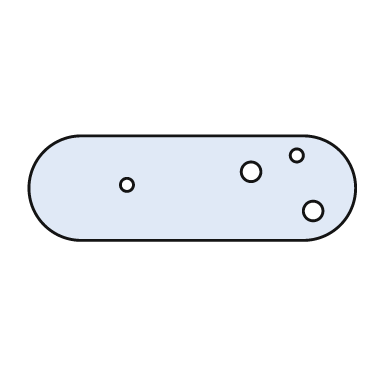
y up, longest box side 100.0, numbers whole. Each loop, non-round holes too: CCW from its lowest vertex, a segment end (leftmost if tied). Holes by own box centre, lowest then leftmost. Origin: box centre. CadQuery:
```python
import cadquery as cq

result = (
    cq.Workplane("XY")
    .moveTo(-34.0, -16.0)
    .lineTo(34.0, -16.0)
    .threePointArc((50.0, 0.0), (34.0, 16.0))
    .lineTo(-34.0, 16.0)
    .threePointArc((-50.0, 0.0), (-34.0, -16.0))
    .close()
    .moveTo(37.0, -7.0)
    .circle(3.0)
    .moveTo(-20.0, 1.0)
    .circle(2.0)
    .moveTo(18.0, 5.0)
    .circle(3.0)
    .moveTo(32.0, 10.0)
    .circle(2.0)
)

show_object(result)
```